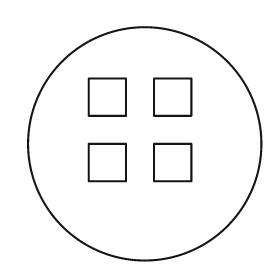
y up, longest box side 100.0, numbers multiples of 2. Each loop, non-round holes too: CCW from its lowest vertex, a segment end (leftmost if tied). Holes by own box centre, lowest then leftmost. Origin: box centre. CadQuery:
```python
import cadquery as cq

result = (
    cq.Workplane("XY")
    .moveTo(0.0, 0.0)
    .circle(50.0)
    .moveTo(-24.0, -16.0)
    .lineTo(-8.0, -16.0)
    .lineTo(-8.0, 0.0)
    .lineTo(-24.0, 0.0)
    .close()
    .moveTo(4.0, -16.0)
    .lineTo(20.0, -16.0)
    .lineTo(20.0, 0.0)
    .lineTo(4.0, 0.0)
    .close()
    .moveTo(-24.0, 12.0)
    .lineTo(-8.0, 12.0)
    .lineTo(-8.0, 28.0)
    .lineTo(-24.0, 28.0)
    .close()
    .moveTo(4.0, 12.0)
    .lineTo(20.0, 12.0)
    .lineTo(20.0, 28.0)
    .lineTo(4.0, 28.0)
    .close()
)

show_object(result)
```